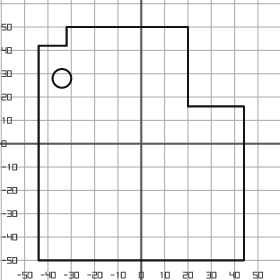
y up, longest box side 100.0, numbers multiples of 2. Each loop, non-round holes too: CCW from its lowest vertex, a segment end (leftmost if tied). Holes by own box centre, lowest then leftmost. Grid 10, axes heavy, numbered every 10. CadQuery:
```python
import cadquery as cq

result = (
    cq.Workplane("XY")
    .moveTo(-44.0, -50.0)
    .lineTo(44.0, -50.0)
    .lineTo(44.0, 16.0)
    .lineTo(20.0, 16.0)
    .lineTo(20.0, 50.0)
    .lineTo(-32.0, 50.0)
    .lineTo(-32.0, 42.0)
    .lineTo(-44.0, 42.0)
    .close()
    .moveTo(-34.0, 28.0)
    .circle(4.0)
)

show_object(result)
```